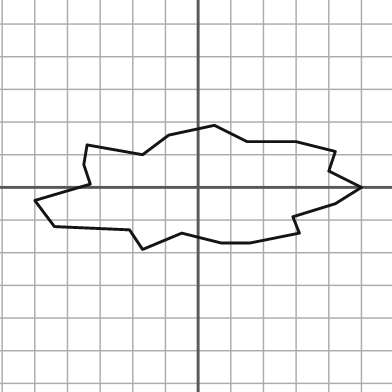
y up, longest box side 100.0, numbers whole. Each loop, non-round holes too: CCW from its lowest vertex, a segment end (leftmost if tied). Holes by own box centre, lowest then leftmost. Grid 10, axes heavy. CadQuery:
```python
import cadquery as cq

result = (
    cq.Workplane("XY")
    .moveTo(-17.0, -19.0)
    .lineTo(-5.0, -14.0)
    .lineTo(7.0, -17.0)
    .lineTo(16.0, -17.0)
    .lineTo(31.0, -14.0)
    .lineTo(29.0, -9.0)
    .lineTo(42.0, -5.0)
    .lineTo(50.0, 0.0)
    .lineTo(40.0, 5.0)
    .lineTo(42.0, 11.0)
    .lineTo(30.0, 14.0)
    .lineTo(15.0, 14.0)
    .lineTo(5.0, 19.0)
    .lineTo(-9.0, 16.0)
    .lineTo(-17.0, 10.0)
    .lineTo(-34.0, 13.0)
    .lineTo(-35.0, 7.0)
    .lineTo(-33.0, 1.0)
    .lineTo(-50.0, -4.0)
    .lineTo(-44.0, -12.0)
    .lineTo(-21.0, -13.0)
    .close()
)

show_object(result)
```